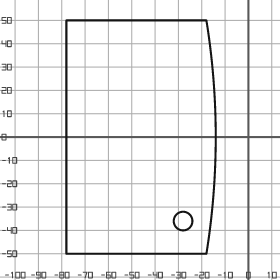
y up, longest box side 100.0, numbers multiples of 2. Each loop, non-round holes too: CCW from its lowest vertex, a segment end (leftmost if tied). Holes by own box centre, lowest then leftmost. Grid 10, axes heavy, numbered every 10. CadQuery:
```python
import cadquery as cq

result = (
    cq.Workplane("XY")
    .moveTo(-78.0, -50.0)
    .lineTo(-18.0, -50.0)
    .threePointArc((-14.0, 0.0), (-18.0, 50.0))
    .lineTo(-78.0, 50.0)
    .close()
    .moveTo(-28.0, -36.0)
    .circle(4.0)
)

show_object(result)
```